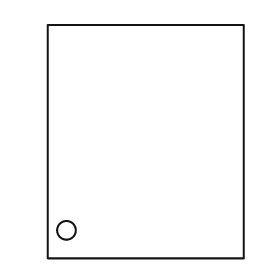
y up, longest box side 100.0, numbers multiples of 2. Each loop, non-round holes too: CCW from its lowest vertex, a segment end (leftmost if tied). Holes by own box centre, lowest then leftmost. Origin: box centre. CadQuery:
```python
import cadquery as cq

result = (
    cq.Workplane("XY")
    .moveTo(-42.0, -50.0)
    .lineTo(42.0, -50.0)
    .lineTo(42.0, 50.0)
    .lineTo(-42.0, 50.0)
    .close()
    .moveTo(-34.0, -38.0)
    .circle(4.0)
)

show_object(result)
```